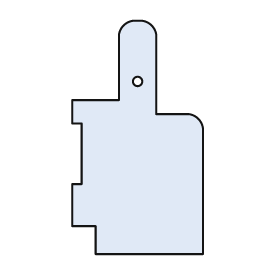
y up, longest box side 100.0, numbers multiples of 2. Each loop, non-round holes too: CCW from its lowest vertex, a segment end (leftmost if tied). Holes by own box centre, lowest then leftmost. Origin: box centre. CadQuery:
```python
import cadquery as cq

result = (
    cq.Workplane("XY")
    .moveTo(-18.0, -50.0)
    .lineTo(28.0, -50.0)
    .lineTo(28.0, 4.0)
    .threePointArc((26.0, 8.0), (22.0, 10.0))
    .lineTo(8.0, 10.0)
    .lineTo(8.0, 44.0)
    .threePointArc((6.0, 48.0), (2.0, 50.0))
    .lineTo(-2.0, 50.0)
    .threePointArc((-6.0, 48.0), (-8.0, 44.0))
    .lineTo(-8.0, 16.0)
    .lineTo(-28.0, 16.0)
    .lineTo(-28.0, 6.0)
    .lineTo(-24.0, 6.0)
    .lineTo(-24.0, -20.0)
    .lineTo(-28.0, -20.0)
    .lineTo(-28.0, -38.0)
    .lineTo(-18.0, -38.0)
    .close()
    .moveTo(0.0, 24.0)
    .circle(2.0)
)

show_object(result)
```